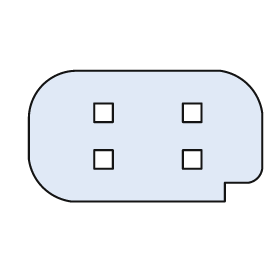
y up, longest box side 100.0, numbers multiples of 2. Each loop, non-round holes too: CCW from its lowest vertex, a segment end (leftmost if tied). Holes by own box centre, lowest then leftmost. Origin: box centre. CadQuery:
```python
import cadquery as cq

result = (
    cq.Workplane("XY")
    .moveTo(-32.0, -28.0)
    .lineTo(34.0, -28.0)
    .lineTo(34.0, -20.0)
    .lineTo(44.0, -20.0)
    .threePointArc((48.0, -18.0), (50.0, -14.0))
    .lineTo(50.0, 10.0)
    .threePointArc((44.0, 22.0), (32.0, 28.0))
    .lineTo(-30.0, 28.0)
    .threePointArc((-44.0, 22.0), (-50.0, 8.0))
    .lineTo(-50.0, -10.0)
    .threePointArc((-44.0, -22.0), (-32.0, -28.0))
    .close()
    .moveTo(-22.0, -14.0)
    .lineTo(-14.0, -14.0)
    .lineTo(-14.0, -6.0)
    .lineTo(-22.0, -6.0)
    .close()
    .moveTo(16.0, -14.0)
    .lineTo(24.0, -14.0)
    .lineTo(24.0, -6.0)
    .lineTo(16.0, -6.0)
    .close()
    .moveTo(-22.0, 6.0)
    .lineTo(-14.0, 6.0)
    .lineTo(-14.0, 14.0)
    .lineTo(-22.0, 14.0)
    .close()
    .moveTo(16.0, 6.0)
    .lineTo(24.0, 6.0)
    .lineTo(24.0, 14.0)
    .lineTo(16.0, 14.0)
    .close()
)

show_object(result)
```